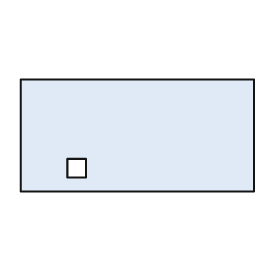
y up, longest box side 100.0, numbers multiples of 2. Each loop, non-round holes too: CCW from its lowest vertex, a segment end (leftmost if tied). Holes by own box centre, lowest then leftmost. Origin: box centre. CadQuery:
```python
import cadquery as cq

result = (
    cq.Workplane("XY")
    .moveTo(-50.0, -24.0)
    .lineTo(50.0, -24.0)
    .lineTo(50.0, 24.0)
    .lineTo(-50.0, 24.0)
    .close()
    .moveTo(-30.0, -18.0)
    .lineTo(-22.0, -18.0)
    .lineTo(-22.0, -10.0)
    .lineTo(-30.0, -10.0)
    .close()
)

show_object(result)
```